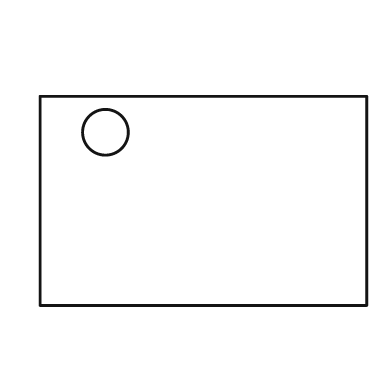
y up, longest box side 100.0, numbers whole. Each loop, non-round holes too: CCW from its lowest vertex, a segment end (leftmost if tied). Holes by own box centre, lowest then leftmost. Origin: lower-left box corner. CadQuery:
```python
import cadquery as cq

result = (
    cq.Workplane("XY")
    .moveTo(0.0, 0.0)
    .lineTo(100.0, 0.0)
    .lineTo(100.0, 64.0)
    .lineTo(0.0, 64.0)
    .close()
    .moveTo(20.0, 53.0)
    .circle(7.0)
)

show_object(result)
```